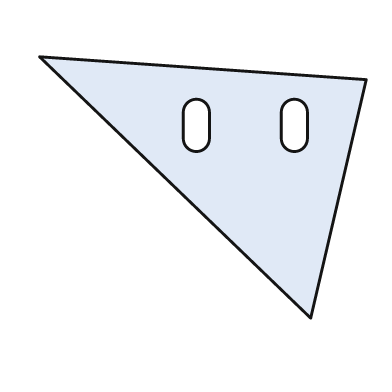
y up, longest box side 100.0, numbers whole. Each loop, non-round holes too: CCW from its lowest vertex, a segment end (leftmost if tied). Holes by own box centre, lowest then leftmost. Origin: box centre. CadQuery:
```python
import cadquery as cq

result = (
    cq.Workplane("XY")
    .moveTo(33.0, -40.0)
    .lineTo(50.0, 33.0)
    .lineTo(-50.0, 40.0)
    .close()
    .moveTo(-6.0, 15.0)
    .threePointArc((-2.0, 11.0), (2.0, 15.0))
    .lineTo(2.0, 23.0)
    .threePointArc((-2.0, 27.0), (-6.0, 23.0))
    .close()
    .moveTo(24.0, 15.0)
    .threePointArc((28.0, 11.0), (32.0, 15.0))
    .lineTo(32.0, 23.0)
    .threePointArc((28.0, 27.0), (24.0, 23.0))
    .close()
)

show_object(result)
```